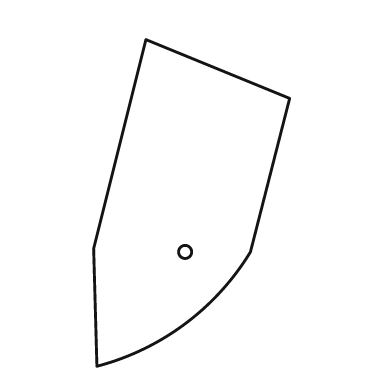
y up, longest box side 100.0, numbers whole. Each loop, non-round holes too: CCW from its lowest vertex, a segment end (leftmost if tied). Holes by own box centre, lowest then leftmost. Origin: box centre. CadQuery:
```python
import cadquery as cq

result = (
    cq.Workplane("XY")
    .moveTo(-29.0, -50.0)
    .threePointArc((-2.0, -37.0), (18.0, -15.0))
    .lineTo(30.0, 32.0)
    .lineTo(-14.0, 50.0)
    .lineTo(-30.0, -14.0)
    .close()
    .moveTo(-2.0, -15.0)
    .circle(2.0)
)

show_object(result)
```